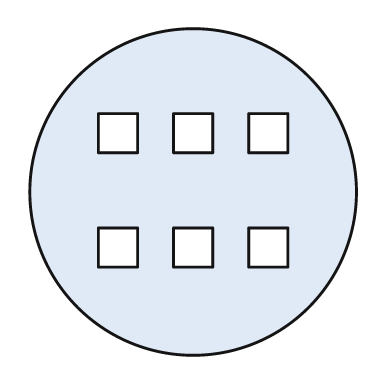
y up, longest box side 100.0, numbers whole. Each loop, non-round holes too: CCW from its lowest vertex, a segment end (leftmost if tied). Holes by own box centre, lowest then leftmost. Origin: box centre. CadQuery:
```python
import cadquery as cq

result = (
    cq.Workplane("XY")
    .moveTo(0.0, 0.0)
    .circle(50.0)
    .moveTo(-29.0, -23.0)
    .lineTo(-17.0, -23.0)
    .lineTo(-17.0, -11.0)
    .lineTo(-29.0, -11.0)
    .close()
    .moveTo(-6.0, -23.0)
    .lineTo(6.0, -23.0)
    .lineTo(6.0, -11.0)
    .lineTo(-6.0, -11.0)
    .close()
    .moveTo(17.0, -23.0)
    .lineTo(29.0, -23.0)
    .lineTo(29.0, -11.0)
    .lineTo(17.0, -11.0)
    .close()
    .moveTo(-29.0, 12.0)
    .lineTo(-17.0, 12.0)
    .lineTo(-17.0, 24.0)
    .lineTo(-29.0, 24.0)
    .close()
    .moveTo(-6.0, 12.0)
    .lineTo(6.0, 12.0)
    .lineTo(6.0, 24.0)
    .lineTo(-6.0, 24.0)
    .close()
    .moveTo(17.0, 12.0)
    .lineTo(29.0, 12.0)
    .lineTo(29.0, 24.0)
    .lineTo(17.0, 24.0)
    .close()
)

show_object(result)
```